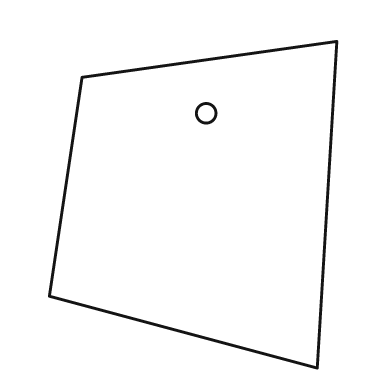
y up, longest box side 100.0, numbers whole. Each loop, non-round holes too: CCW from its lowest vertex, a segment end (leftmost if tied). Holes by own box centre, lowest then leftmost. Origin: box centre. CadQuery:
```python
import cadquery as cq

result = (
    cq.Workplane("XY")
    .moveTo(38.0, -50.0)
    .lineTo(44.0, 50.0)
    .lineTo(-34.0, 39.0)
    .lineTo(-44.0, -28.0)
    .close()
    .moveTo(4.0, 28.0)
    .circle(3.0)
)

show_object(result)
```